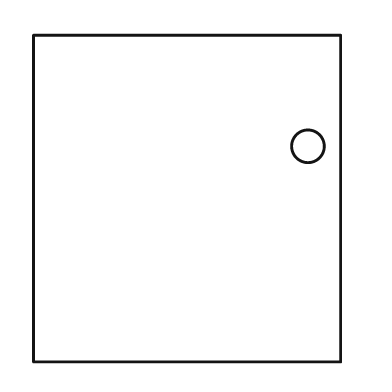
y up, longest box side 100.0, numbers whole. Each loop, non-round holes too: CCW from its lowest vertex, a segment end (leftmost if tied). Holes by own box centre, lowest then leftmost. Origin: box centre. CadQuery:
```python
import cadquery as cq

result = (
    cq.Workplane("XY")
    .moveTo(-47.0, -50.0)
    .lineTo(47.0, -50.0)
    .lineTo(47.0, 50.0)
    .lineTo(-47.0, 50.0)
    .close()
    .moveTo(37.0, 16.0)
    .circle(5.0)
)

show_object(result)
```